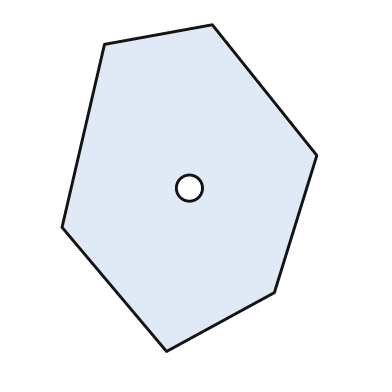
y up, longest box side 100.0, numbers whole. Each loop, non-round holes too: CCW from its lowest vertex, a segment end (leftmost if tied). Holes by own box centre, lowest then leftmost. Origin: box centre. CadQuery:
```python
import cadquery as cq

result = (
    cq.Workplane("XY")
    .moveTo(-7.0, -50.0)
    .lineTo(26.0, -32.0)
    .lineTo(39.0, 10.0)
    .lineTo(7.0, 50.0)
    .lineTo(-26.0, 44.0)
    .lineTo(-39.0, -12.0)
    .close()
    .moveTo(0.0, 0.0)
    .circle(4.0)
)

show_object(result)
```